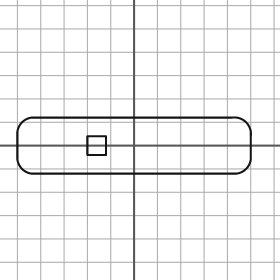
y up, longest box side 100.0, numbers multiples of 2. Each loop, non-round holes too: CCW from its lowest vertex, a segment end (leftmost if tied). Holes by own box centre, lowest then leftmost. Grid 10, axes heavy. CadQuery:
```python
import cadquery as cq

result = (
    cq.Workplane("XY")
    .moveTo(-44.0, -12.0)
    .lineTo(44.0, -12.0)
    .threePointArc((48.0, -10.0), (50.0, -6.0))
    .lineTo(50.0, 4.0)
    .threePointArc((48.0, 10.0), (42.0, 12.0))
    .lineTo(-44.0, 12.0)
    .threePointArc((-48.0, 10.0), (-50.0, 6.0))
    .lineTo(-50.0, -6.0)
    .threePointArc((-48.0, -10.0), (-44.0, -12.0))
    .close()
    .moveTo(-20.0, -4.0)
    .lineTo(-12.0, -4.0)
    .lineTo(-12.0, 4.0)
    .lineTo(-20.0, 4.0)
    .close()
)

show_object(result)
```